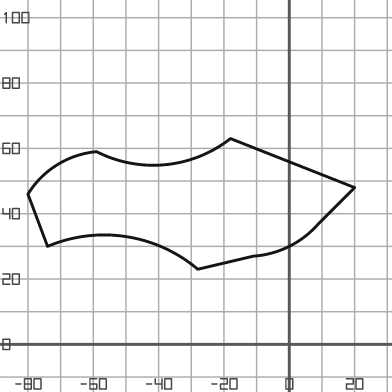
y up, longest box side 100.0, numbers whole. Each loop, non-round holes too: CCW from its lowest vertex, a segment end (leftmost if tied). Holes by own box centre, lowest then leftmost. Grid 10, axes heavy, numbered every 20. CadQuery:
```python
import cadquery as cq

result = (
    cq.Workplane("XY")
    .moveTo(-28.0, 23.0)
    .lineTo(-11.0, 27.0)
    .threePointArc((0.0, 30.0), (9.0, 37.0))
    .lineTo(20.0, 48.0)
    .lineTo(-18.0, 63.0)
    .threePointArc((-38.0, 55.0), (-59.0, 59.0))
    .threePointArc((-71.0, 55.0), (-80.0, 46.0))
    .lineTo(-74.0, 30.0)
    .threePointArc((-50.0, 33.0), (-28.0, 23.0))
    .close()
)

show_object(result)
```